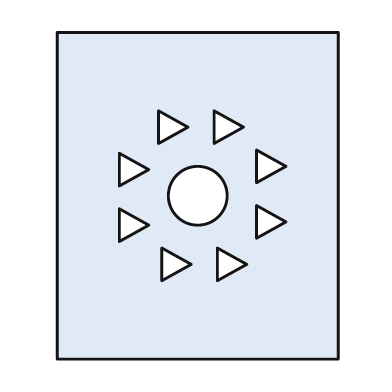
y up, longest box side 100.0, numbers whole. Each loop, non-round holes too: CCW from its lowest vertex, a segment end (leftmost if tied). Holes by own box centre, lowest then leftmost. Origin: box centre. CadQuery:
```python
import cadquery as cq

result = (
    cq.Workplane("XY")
    .moveTo(-43.0, -50.0)
    .lineTo(43.0, -50.0)
    .lineTo(43.0, 50.0)
    .lineTo(-43.0, 50.0)
    .close()
    .moveTo(-11.0, -26.0)
    .lineTo(-2.0, -21.0)
    .lineTo(-11.0, -16.0)
    .close()
    .moveTo(6.0, -26.0)
    .lineTo(15.0, -21.0)
    .lineTo(6.0, -16.0)
    .close()
    .moveTo(-24.0, -14.0)
    .lineTo(-15.0, -9.0)
    .lineTo(-24.0, -4.0)
    .close()
    .moveTo(18.0, -13.0)
    .lineTo(27.0, -8.0)
    .lineTo(18.0, -3.0)
    .close()
    .moveTo(0.0, 0.0)
    .circle(9.0)
    .moveTo(-24.0, 3.0)
    .lineTo(-15.0, 8.0)
    .lineTo(-24.0, 13.0)
    .close()
    .moveTo(18.0, 4.0)
    .lineTo(27.0, 9.0)
    .lineTo(18.0, 14.0)
    .close()
    .moveTo(-12.0, 16.0)
    .lineTo(-3.0, 21.0)
    .lineTo(-12.0, 26.0)
    .close()
    .moveTo(5.0, 16.0)
    .lineTo(14.0, 21.0)
    .lineTo(5.0, 26.0)
    .close()
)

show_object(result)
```